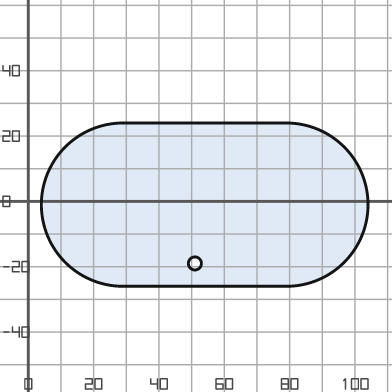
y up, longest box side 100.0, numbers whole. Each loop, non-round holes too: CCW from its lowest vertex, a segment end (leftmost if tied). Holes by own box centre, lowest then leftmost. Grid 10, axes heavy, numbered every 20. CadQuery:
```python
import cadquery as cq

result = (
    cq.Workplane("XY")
    .moveTo(29.0, -26.0)
    .lineTo(79.0, -26.0)
    .threePointArc((104.0, -1.0), (79.0, 24.0))
    .lineTo(29.0, 24.0)
    .threePointArc((4.0, -1.0), (29.0, -26.0))
    .close()
    .moveTo(51.0, -19.0)
    .circle(2.0)
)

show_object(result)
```